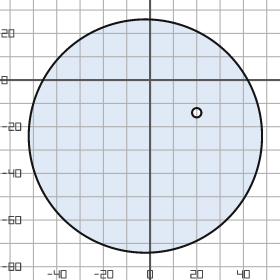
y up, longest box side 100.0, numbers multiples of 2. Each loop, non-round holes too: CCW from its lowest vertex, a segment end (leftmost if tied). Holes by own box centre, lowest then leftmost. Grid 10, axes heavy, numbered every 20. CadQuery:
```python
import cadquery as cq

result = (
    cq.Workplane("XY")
    .moveTo(-2.0, -24.0)
    .circle(50.0)
    .moveTo(20.0, -14.0)
    .circle(2.0)
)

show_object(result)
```